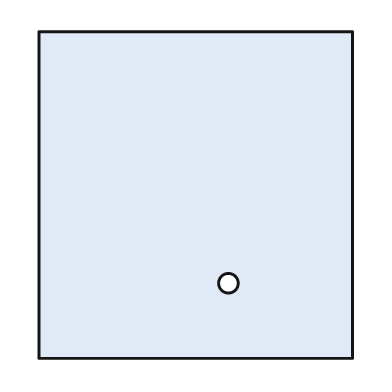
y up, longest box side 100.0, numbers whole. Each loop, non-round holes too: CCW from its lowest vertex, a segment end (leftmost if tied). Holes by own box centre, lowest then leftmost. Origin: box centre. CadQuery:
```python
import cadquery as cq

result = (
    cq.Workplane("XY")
    .moveTo(-48.0, -50.0)
    .lineTo(48.0, -50.0)
    .lineTo(48.0, 50.0)
    .lineTo(-48.0, 50.0)
    .close()
    .moveTo(10.0, -27.0)
    .circle(3.0)
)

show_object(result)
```